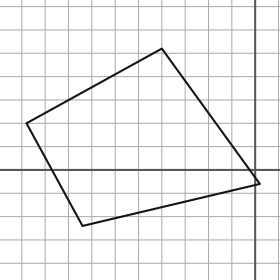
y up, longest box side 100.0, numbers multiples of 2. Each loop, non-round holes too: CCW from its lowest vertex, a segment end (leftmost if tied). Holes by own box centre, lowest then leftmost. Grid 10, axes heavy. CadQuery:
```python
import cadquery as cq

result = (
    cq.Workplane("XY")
    .moveTo(-74.0, -24.0)
    .lineTo(2.0, -6.0)
    .lineTo(-40.0, 52.0)
    .lineTo(-98.0, 20.0)
    .close()
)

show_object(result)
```